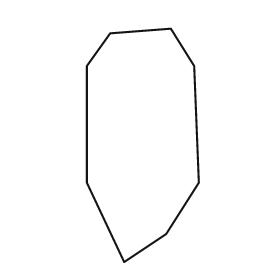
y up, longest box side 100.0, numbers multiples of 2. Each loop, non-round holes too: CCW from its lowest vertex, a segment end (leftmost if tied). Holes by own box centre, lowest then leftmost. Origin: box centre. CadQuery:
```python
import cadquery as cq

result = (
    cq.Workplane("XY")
    .moveTo(-8.0, -50.0)
    .lineTo(10.0, -38.0)
    .lineTo(24.0, -16.0)
    .lineTo(22.0, 34.0)
    .lineTo(12.0, 50.0)
    .lineTo(-14.0, 48.0)
    .lineTo(-24.0, 34.0)
    .lineTo(-24.0, -16.0)
    .close()
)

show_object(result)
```